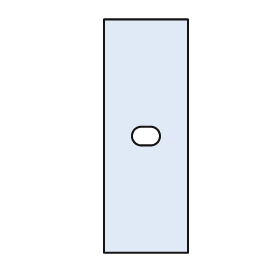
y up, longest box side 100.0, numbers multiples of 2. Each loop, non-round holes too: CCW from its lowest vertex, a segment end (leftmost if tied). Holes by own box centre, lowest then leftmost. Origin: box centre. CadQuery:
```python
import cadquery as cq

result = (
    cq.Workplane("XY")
    .moveTo(-18.0, -50.0)
    .lineTo(18.0, -50.0)
    .lineTo(18.0, 50.0)
    .lineTo(-18.0, 50.0)
    .close()
    .moveTo(-2.0, -4.0)
    .lineTo(2.0, -4.0)
    .threePointArc((6.0, 0.0), (2.0, 4.0))
    .lineTo(-2.0, 4.0)
    .threePointArc((-6.0, 0.0), (-2.0, -4.0))
    .close()
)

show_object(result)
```